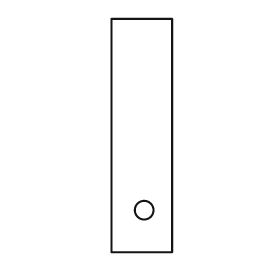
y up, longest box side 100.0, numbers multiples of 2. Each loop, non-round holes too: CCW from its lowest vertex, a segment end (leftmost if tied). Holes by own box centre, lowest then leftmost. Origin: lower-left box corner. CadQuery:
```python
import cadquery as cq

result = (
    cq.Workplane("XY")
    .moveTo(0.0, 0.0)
    .lineTo(26.0, 0.0)
    .lineTo(26.0, 100.0)
    .lineTo(0.0, 100.0)
    .close()
    .moveTo(14.0, 18.0)
    .circle(4.0)
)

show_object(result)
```